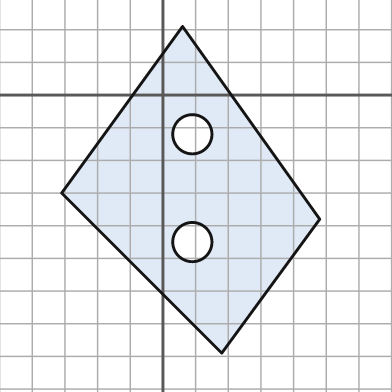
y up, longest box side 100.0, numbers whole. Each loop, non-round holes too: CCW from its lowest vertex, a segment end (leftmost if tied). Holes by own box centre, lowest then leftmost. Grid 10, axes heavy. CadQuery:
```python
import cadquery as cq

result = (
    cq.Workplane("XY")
    .moveTo(18.0, -79.0)
    .lineTo(48.0, -38.0)
    .lineTo(6.0, 21.0)
    .lineTo(-31.0, -30.0)
    .close()
    .moveTo(9.0, -45.0)
    .circle(6.0)
    .moveTo(9.0, -12.0)
    .circle(6.0)
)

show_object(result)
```